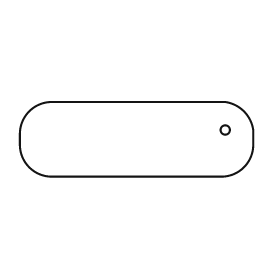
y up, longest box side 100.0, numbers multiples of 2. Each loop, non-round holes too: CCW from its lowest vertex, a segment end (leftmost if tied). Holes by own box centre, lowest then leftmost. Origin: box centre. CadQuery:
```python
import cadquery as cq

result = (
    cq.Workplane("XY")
    .moveTo(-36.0, -16.0)
    .lineTo(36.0, -16.0)
    .threePointArc((46.0, -12.0), (50.0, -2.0))
    .lineTo(50.0, 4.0)
    .threePointArc((46.0, 12.0), (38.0, 16.0))
    .lineTo(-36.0, 16.0)
    .threePointArc((-46.0, 12.0), (-50.0, 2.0))
    .lineTo(-50.0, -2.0)
    .threePointArc((-46.0, -12.0), (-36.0, -16.0))
    .close()
    .moveTo(38.0, 4.0)
    .circle(2.0)
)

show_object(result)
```